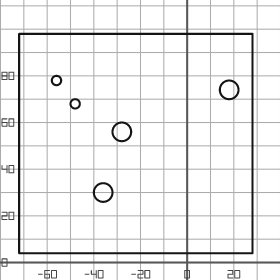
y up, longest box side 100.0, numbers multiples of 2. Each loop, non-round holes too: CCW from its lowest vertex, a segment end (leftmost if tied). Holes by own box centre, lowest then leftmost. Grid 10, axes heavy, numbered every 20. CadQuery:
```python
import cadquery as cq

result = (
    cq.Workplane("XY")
    .moveTo(-72.0, 4.0)
    .lineTo(28.0, 4.0)
    .lineTo(28.0, 98.0)
    .lineTo(-72.0, 98.0)
    .close()
    .moveTo(-36.0, 30.0)
    .circle(4.0)
    .moveTo(-28.0, 56.0)
    .circle(4.0)
    .moveTo(-48.0, 68.0)
    .circle(2.0)
    .moveTo(18.0, 74.0)
    .circle(4.0)
    .moveTo(-56.0, 78.0)
    .circle(2.0)
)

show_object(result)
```